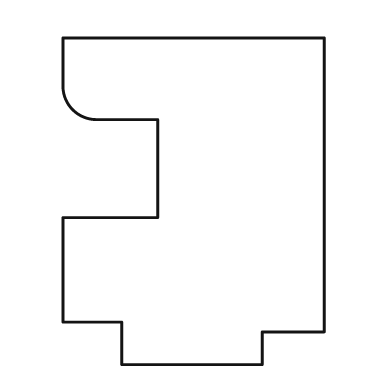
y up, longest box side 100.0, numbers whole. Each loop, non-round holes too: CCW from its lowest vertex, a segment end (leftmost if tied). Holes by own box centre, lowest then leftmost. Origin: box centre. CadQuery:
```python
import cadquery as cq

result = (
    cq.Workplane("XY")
    .moveTo(-22.0, -50.0)
    .lineTo(21.0, -50.0)
    .lineTo(21.0, -40.0)
    .lineTo(40.0, -40.0)
    .lineTo(40.0, 50.0)
    .lineTo(-40.0, 50.0)
    .lineTo(-40.0, 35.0)
    .threePointArc((-37.0, 28.0), (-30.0, 25.0))
    .lineTo(-11.0, 25.0)
    .lineTo(-11.0, -5.0)
    .lineTo(-40.0, -5.0)
    .lineTo(-40.0, -37.0)
    .lineTo(-22.0, -37.0)
    .close()
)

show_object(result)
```